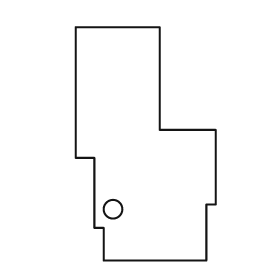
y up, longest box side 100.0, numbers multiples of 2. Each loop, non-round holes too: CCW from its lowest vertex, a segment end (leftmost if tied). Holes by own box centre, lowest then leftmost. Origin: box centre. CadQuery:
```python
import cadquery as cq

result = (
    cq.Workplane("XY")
    .moveTo(-18.0, -50.0)
    .lineTo(26.0, -50.0)
    .lineTo(26.0, -26.0)
    .lineTo(30.0, -26.0)
    .lineTo(30.0, 6.0)
    .lineTo(6.0, 6.0)
    .lineTo(6.0, 50.0)
    .lineTo(-30.0, 50.0)
    .lineTo(-30.0, -6.0)
    .lineTo(-22.0, -6.0)
    .lineTo(-22.0, -36.0)
    .lineTo(-18.0, -36.0)
    .close()
    .moveTo(-14.0, -28.0)
    .circle(4.0)
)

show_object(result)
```